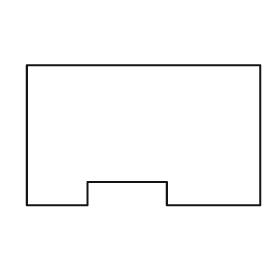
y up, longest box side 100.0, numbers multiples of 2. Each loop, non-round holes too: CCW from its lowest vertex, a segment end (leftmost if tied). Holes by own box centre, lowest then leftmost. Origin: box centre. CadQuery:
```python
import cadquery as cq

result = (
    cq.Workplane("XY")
    .moveTo(-50.0, -30.0)
    .lineTo(-24.0, -30.0)
    .lineTo(-24.0, -20.0)
    .lineTo(10.0, -20.0)
    .lineTo(10.0, -30.0)
    .lineTo(50.0, -30.0)
    .lineTo(50.0, 30.0)
    .lineTo(-50.0, 30.0)
    .close()
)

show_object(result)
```